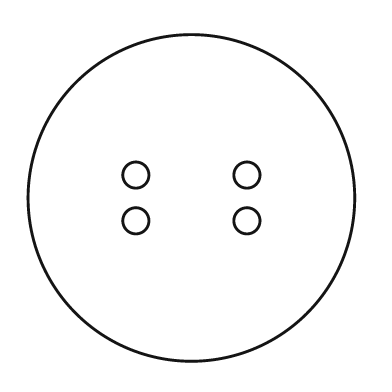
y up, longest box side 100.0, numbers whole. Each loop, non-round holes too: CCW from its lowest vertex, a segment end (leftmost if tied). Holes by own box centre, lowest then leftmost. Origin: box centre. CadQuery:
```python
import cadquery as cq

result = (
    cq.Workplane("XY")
    .moveTo(0.0, 0.0)
    .circle(50.0)
    .moveTo(-17.0, -7.0)
    .circle(4.0)
    .moveTo(17.0, -7.0)
    .circle(4.0)
    .moveTo(-17.0, 7.0)
    .circle(4.0)
    .moveTo(17.0, 7.0)
    .circle(4.0)
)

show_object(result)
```